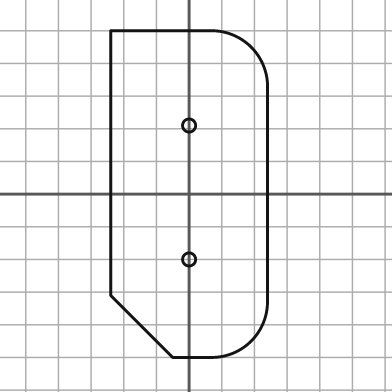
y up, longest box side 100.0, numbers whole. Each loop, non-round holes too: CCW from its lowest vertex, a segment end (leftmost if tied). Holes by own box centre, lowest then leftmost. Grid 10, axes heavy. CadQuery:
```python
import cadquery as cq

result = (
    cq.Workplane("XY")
    .moveTo(-5.0, -50.0)
    .lineTo(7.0, -50.0)
    .threePointArc((19.0, -45.0), (24.0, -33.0))
    .lineTo(24.0, 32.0)
    .threePointArc((19.0, 45.0), (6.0, 50.0))
    .lineTo(-24.0, 50.0)
    .lineTo(-24.0, -31.0)
    .close()
    .moveTo(0.0, -20.0)
    .circle(2.0)
    .moveTo(0.0, 21.0)
    .circle(2.0)
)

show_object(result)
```